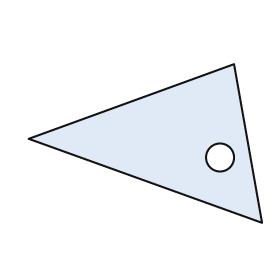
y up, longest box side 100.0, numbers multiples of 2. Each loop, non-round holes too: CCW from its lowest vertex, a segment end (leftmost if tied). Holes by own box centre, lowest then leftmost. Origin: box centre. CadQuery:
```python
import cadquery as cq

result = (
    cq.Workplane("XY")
    .moveTo(50.0, -34.0)
    .lineTo(38.0, 34.0)
    .lineTo(-50.0, 2.0)
    .close()
    .moveTo(32.0, -6.0)
    .circle(6.0)
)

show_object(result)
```